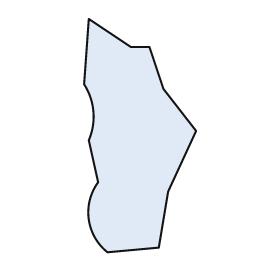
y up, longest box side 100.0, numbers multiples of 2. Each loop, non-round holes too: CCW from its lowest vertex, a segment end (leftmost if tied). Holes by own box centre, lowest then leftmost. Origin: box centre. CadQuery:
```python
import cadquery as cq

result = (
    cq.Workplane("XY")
    .moveTo(-14.0, -50.0)
    .lineTo(8.0, -48.0)
    .lineTo(12.0, -24.0)
    .lineTo(24.0, 2.0)
    .lineTo(10.0, 20.0)
    .lineTo(4.0, 38.0)
    .lineTo(-4.0, 38.0)
    .lineTo(-22.0, 50.0)
    .lineTo(-24.0, 22.0)
    .threePointArc((-20.0, 10.0), (-22.0, -2.0))
    .lineTo(-18.0, -20.0)
    .threePointArc((-22.0, -36.0), (-14.0, -50.0))
    .close()
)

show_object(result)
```